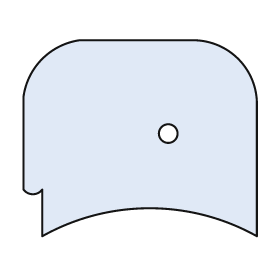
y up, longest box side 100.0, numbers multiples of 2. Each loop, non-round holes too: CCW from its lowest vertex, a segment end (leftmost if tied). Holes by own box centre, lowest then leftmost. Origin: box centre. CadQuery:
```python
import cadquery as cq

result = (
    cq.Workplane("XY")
    .moveTo(-42.0, -42.0)
    .threePointArc((4.0, -30.0), (50.0, -42.0))
    .lineTo(50.0, 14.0)
    .threePointArc((42.0, 34.0), (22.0, 42.0))
    .lineTo(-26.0, 42.0)
    .threePointArc((-42.0, 34.0), (-50.0, 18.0))
    .lineTo(-50.0, -22.0)
    .threePointArc((-46.0, -24.0), (-42.0, -22.0))
    .close()
    .moveTo(12.0, 2.0)
    .circle(4.0)
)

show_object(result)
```